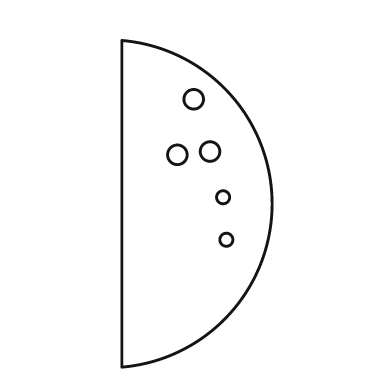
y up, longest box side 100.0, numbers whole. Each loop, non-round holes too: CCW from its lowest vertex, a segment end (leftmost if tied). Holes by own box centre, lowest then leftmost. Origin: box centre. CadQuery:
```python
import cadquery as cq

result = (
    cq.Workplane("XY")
    .moveTo(-23.0, -50.0)
    .threePointArc((23.0, 0.0), (-23.0, 50.0))
    .close()
    .moveTo(9.0, -11.0)
    .circle(2.0)
    .moveTo(8.0, 2.0)
    .circle(2.0)
    .moveTo(-6.0, 15.0)
    .circle(3.0)
    .moveTo(4.0, 16.0)
    .circle(3.0)
    .moveTo(-1.0, 32.0)
    .circle(3.0)
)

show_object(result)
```